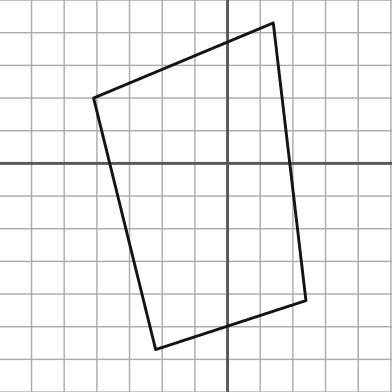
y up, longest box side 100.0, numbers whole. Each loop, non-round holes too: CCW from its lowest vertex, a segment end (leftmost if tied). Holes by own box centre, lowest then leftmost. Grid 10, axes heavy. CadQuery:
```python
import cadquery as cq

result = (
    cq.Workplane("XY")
    .moveTo(-22.0, -57.0)
    .lineTo(24.0, -42.0)
    .lineTo(14.0, 43.0)
    .lineTo(-41.0, 20.0)
    .close()
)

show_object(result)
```